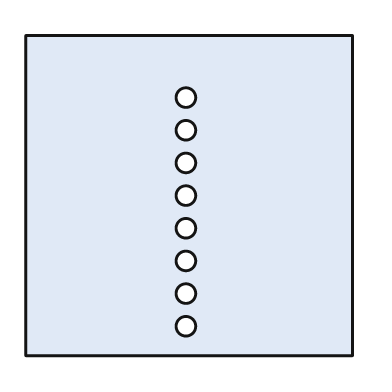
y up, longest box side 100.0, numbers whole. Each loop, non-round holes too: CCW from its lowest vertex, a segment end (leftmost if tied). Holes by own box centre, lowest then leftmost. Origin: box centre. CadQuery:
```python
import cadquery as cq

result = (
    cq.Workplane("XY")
    .moveTo(-50.0, -49.0)
    .lineTo(50.0, -49.0)
    .lineTo(50.0, 49.0)
    .lineTo(-50.0, 49.0)
    .close()
    .moveTo(-1.0, -40.0)
    .circle(3.0)
    .moveTo(-1.0, -30.0)
    .circle(3.0)
    .moveTo(-1.0, -20.0)
    .circle(3.0)
    .moveTo(-1.0, -10.0)
    .circle(3.0)
    .moveTo(-1.0, 0.0)
    .circle(3.0)
    .moveTo(-1.0, 10.0)
    .circle(3.0)
    .moveTo(-1.0, 20.0)
    .circle(3.0)
    .moveTo(-1.0, 30.0)
    .circle(3.0)
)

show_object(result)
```